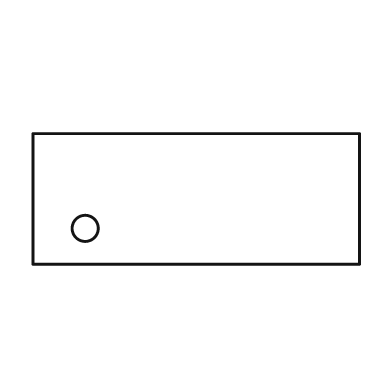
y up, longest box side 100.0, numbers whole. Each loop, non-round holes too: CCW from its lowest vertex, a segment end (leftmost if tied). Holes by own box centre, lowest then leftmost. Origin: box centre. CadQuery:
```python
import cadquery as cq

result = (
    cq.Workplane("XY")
    .moveTo(-50.0, -20.0)
    .lineTo(50.0, -20.0)
    .lineTo(50.0, 20.0)
    .lineTo(-50.0, 20.0)
    .close()
    .moveTo(-34.0, -9.0)
    .circle(4.0)
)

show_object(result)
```